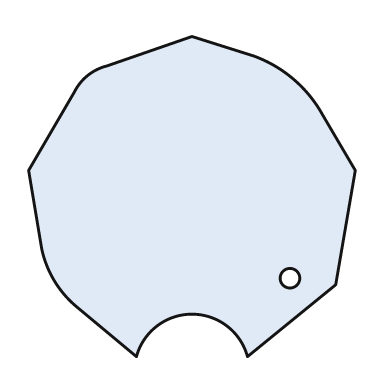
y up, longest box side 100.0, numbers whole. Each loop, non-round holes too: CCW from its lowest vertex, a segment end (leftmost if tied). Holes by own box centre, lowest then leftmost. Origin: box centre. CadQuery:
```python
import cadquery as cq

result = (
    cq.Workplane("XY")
    .moveTo(-17.0, -49.0)
    .threePointArc((0.0, -36.0), (17.0, -49.0))
    .lineTo(44.0, -27.0)
    .lineTo(50.0, 8.0)
    .lineTo(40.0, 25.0)
    .threePointArc((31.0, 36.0), (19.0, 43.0))
    .lineTo(0.0, 49.0)
    .lineTo(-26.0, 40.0)
    .threePointArc((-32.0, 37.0), (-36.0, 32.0))
    .lineTo(-50.0, 8.0)
    .lineTo(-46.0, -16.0)
    .threePointArc((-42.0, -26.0), (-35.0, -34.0))
    .close()
    .moveTo(30.0, -25.0)
    .circle(3.0)
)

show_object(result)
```